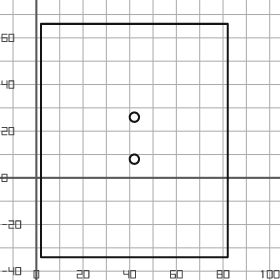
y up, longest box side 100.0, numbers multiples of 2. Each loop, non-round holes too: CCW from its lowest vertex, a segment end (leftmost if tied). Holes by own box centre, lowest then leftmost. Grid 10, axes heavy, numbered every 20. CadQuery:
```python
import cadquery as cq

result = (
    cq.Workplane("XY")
    .moveTo(2.0, -34.0)
    .lineTo(82.0, -34.0)
    .lineTo(82.0, 66.0)
    .lineTo(2.0, 66.0)
    .close()
    .moveTo(42.0, 8.0)
    .circle(2.0)
    .moveTo(42.0, 26.0)
    .circle(2.0)
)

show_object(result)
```